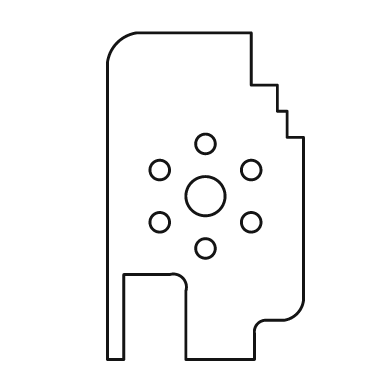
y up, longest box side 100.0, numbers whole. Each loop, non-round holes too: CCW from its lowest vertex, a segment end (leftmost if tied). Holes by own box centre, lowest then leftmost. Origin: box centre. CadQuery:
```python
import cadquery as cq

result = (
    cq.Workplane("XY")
    .moveTo(-30.0, -50.0)
    .lineTo(-25.0, -50.0)
    .lineTo(-25.0, -24.0)
    .lineTo(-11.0, -24.0)
    .threePointArc((-7.0, -25.0), (-6.0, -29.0))
    .lineTo(-6.0, -50.0)
    .lineTo(15.0, -50.0)
    .lineTo(15.0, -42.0)
    .threePointArc((16.0, -39.0), (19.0, -38.0))
    .lineTo(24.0, -38.0)
    .threePointArc((28.0, -36.0), (30.0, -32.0))
    .lineTo(30.0, 18.0)
    .lineTo(25.0, 18.0)
    .lineTo(25.0, 26.0)
    .lineTo(22.0, 26.0)
    .lineTo(22.0, 34.0)
    .lineTo(14.0, 34.0)
    .lineTo(14.0, 50.0)
    .lineTo(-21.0, 50.0)
    .threePointArc((-27.0, 47.0), (-30.0, 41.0))
    .close()
    .moveTo(0.0, -16.0)
    .circle(3.0)
    .moveTo(-14.0, -8.0)
    .circle(3.0)
    .moveTo(14.0, -8.0)
    .circle(3.0)
    .moveTo(0.0, 0.0)
    .circle(6.0)
    .moveTo(-14.0, 8.0)
    .circle(3.0)
    .moveTo(14.0, 8.0)
    .circle(3.0)
    .moveTo(0.0, 16.0)
    .circle(3.0)
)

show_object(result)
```